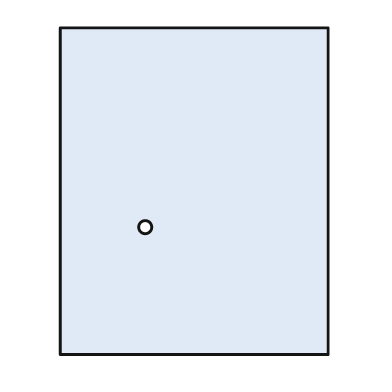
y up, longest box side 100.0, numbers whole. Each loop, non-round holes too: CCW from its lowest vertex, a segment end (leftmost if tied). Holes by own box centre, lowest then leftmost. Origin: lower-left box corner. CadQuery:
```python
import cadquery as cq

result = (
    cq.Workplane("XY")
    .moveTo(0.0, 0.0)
    .lineTo(82.0, 0.0)
    .lineTo(82.0, 100.0)
    .lineTo(0.0, 100.0)
    .close()
    .moveTo(26.0, 39.0)
    .circle(2.0)
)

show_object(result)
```